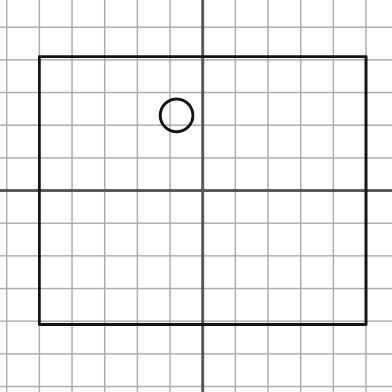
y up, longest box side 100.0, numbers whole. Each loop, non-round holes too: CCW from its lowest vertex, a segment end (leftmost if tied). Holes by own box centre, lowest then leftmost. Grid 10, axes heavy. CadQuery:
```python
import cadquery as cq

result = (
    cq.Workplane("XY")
    .moveTo(-50.0, -41.0)
    .lineTo(50.0, -41.0)
    .lineTo(50.0, 41.0)
    .lineTo(-50.0, 41.0)
    .close()
    .moveTo(-8.0, 23.0)
    .circle(5.0)
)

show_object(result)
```